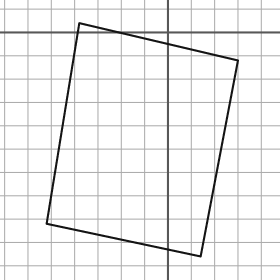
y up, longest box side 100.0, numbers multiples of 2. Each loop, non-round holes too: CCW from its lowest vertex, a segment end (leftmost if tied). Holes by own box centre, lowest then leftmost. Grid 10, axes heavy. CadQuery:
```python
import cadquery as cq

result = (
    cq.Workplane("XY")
    .moveTo(14.0, -96.0)
    .lineTo(30.0, -12.0)
    .lineTo(-38.0, 4.0)
    .lineTo(-52.0, -82.0)
    .close()
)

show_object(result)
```